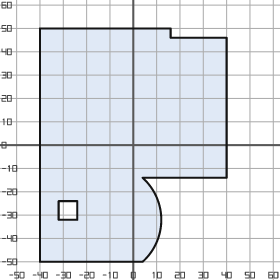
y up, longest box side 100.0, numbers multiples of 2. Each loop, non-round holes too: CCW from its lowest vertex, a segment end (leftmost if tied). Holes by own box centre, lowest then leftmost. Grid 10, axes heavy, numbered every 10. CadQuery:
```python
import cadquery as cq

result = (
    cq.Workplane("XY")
    .moveTo(-40.0, -50.0)
    .lineTo(4.0, -50.0)
    .threePointArc((12.0, -32.0), (4.0, -14.0))
    .lineTo(40.0, -14.0)
    .lineTo(40.0, 46.0)
    .lineTo(16.0, 46.0)
    .lineTo(16.0, 50.0)
    .lineTo(-40.0, 50.0)
    .close()
    .moveTo(-32.0, -32.0)
    .lineTo(-24.0, -32.0)
    .lineTo(-24.0, -24.0)
    .lineTo(-32.0, -24.0)
    .close()
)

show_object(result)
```